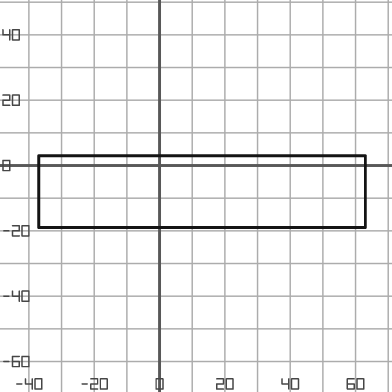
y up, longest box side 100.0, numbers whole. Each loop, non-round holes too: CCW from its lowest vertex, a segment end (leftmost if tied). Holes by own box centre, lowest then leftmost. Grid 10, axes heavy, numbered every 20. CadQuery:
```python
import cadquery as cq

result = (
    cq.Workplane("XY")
    .moveTo(-37.0, -19.0)
    .lineTo(63.0, -19.0)
    .lineTo(63.0, 3.0)
    .lineTo(-37.0, 3.0)
    .close()
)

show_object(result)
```